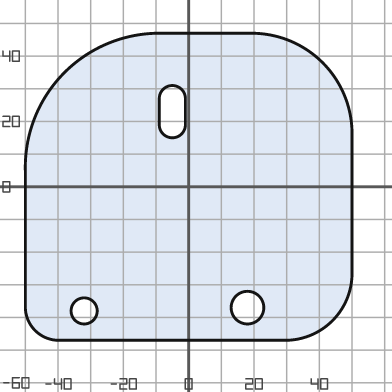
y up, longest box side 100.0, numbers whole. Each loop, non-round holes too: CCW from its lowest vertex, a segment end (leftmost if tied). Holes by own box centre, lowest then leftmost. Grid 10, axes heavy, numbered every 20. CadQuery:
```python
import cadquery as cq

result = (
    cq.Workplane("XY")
    .moveTo(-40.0, -47.0)
    .lineTo(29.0, -47.0)
    .threePointArc((44.0, -41.0), (50.0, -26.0))
    .lineTo(50.0, 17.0)
    .threePointArc((41.0, 38.0), (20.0, 47.0))
    .lineTo(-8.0, 47.0)
    .threePointArc((-38.0, 35.0), (-50.0, 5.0))
    .lineTo(-50.0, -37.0)
    .threePointArc((-47.0, -44.0), (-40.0, -47.0))
    .close()
    .moveTo(-32.0, -38.0)
    .circle(4.0)
    .moveTo(18.0, -37.0)
    .circle(5.0)
    .moveTo(-9.0, 19.0)
    .threePointArc((-5.0, 15.0), (-1.0, 19.0))
    .lineTo(-1.0, 27.0)
    .threePointArc((-5.0, 31.0), (-9.0, 27.0))
    .close()
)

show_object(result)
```